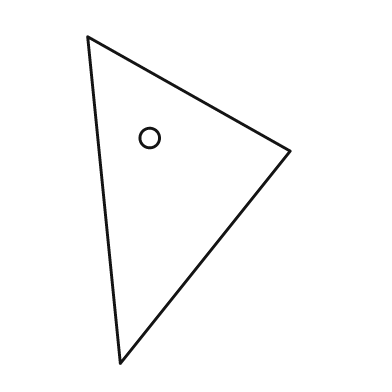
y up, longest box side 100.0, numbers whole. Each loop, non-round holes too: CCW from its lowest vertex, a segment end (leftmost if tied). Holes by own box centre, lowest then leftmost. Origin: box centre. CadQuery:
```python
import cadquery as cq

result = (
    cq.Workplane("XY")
    .moveTo(-21.0, -50.0)
    .lineTo(31.0, 15.0)
    .lineTo(-31.0, 50.0)
    .close()
    .moveTo(-12.0, 19.0)
    .circle(3.0)
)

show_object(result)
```